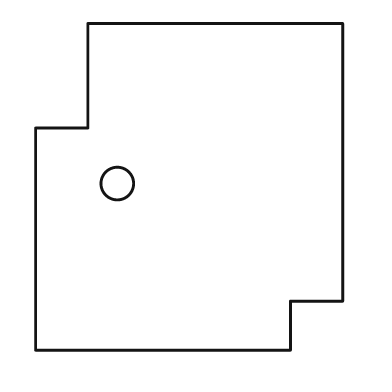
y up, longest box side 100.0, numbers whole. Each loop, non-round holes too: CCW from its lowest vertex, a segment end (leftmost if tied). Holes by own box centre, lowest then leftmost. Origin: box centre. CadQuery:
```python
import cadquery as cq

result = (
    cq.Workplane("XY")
    .moveTo(-47.0, -50.0)
    .lineTo(31.0, -50.0)
    .lineTo(31.0, -35.0)
    .lineTo(47.0, -35.0)
    .lineTo(47.0, 50.0)
    .lineTo(-31.0, 50.0)
    .lineTo(-31.0, 18.0)
    .lineTo(-47.0, 18.0)
    .close()
    .moveTo(-22.0, 1.0)
    .circle(5.0)
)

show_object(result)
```